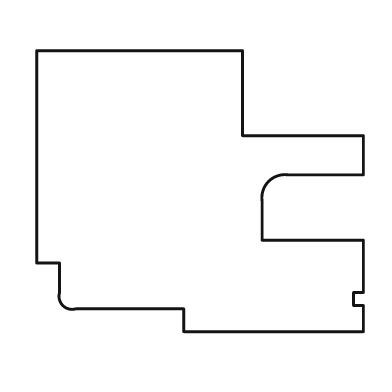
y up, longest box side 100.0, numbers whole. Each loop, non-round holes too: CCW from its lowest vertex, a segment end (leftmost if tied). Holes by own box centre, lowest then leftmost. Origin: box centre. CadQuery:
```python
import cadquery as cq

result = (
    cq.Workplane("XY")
    .moveTo(-5.0, -43.0)
    .lineTo(50.0, -43.0)
    .lineTo(50.0, -35.0)
    .lineTo(47.0, -35.0)
    .lineTo(47.0, -31.0)
    .lineTo(50.0, -31.0)
    .lineTo(50.0, -15.0)
    .lineTo(19.0, -15.0)
    .lineTo(19.0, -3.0)
    .threePointArc((21.0, 3.0), (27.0, 5.0))
    .lineTo(50.0, 5.0)
    .lineTo(50.0, 17.0)
    .lineTo(13.0, 17.0)
    .lineTo(13.0, 43.0)
    .lineTo(-50.0, 43.0)
    .lineTo(-50.0, -22.0)
    .lineTo(-43.0, -22.0)
    .lineTo(-43.0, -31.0)
    .threePointArc((-42.0, -35.0), (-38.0, -36.0))
    .lineTo(-5.0, -36.0)
    .close()
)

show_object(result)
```